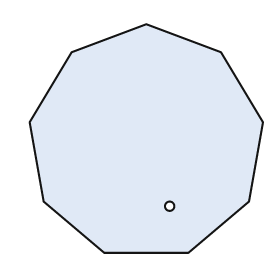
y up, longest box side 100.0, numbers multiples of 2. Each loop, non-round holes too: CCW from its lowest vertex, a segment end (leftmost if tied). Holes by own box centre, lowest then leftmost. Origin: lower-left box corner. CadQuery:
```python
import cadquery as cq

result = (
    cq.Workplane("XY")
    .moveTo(32.0, 0.0)
    .lineTo(68.0, 0.0)
    .lineTo(94.0, 22.0)
    .lineTo(100.0, 56.0)
    .lineTo(82.0, 86.0)
    .lineTo(50.0, 98.0)
    .lineTo(18.0, 86.0)
    .lineTo(0.0, 56.0)
    .lineTo(6.0, 22.0)
    .close()
    .moveTo(60.0, 20.0)
    .circle(2.0)
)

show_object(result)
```